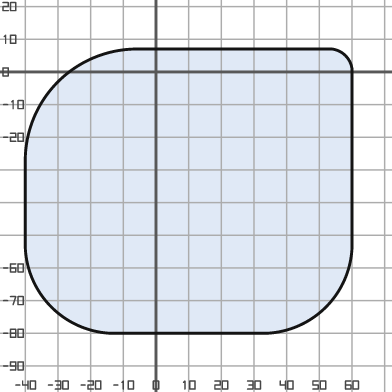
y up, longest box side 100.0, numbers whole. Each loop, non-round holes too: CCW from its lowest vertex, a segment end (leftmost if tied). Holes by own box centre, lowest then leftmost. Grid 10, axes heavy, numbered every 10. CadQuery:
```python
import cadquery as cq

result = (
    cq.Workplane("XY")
    .moveTo(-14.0, -80.0)
    .lineTo(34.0, -80.0)
    .threePointArc((52.0, -72.0), (60.0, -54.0))
    .lineTo(60.0, 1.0)
    .threePointArc((58.0, 5.0), (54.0, 7.0))
    .lineTo(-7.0, 7.0)
    .threePointArc((-30.0, -3.0), (-40.0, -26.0))
    .lineTo(-40.0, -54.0)
    .threePointArc((-32.0, -72.0), (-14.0, -80.0))
    .close()
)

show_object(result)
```